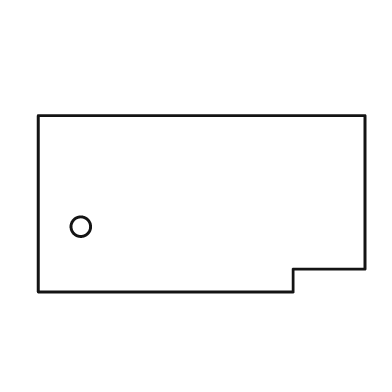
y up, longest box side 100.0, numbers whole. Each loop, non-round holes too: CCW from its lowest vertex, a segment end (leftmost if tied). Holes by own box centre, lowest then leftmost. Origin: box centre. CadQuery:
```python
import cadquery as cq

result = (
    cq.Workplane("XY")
    .moveTo(-50.0, -27.0)
    .lineTo(28.0, -27.0)
    .lineTo(28.0, -20.0)
    .lineTo(50.0, -20.0)
    .lineTo(50.0, 27.0)
    .lineTo(-50.0, 27.0)
    .close()
    .moveTo(-37.0, -7.0)
    .circle(3.0)
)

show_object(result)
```